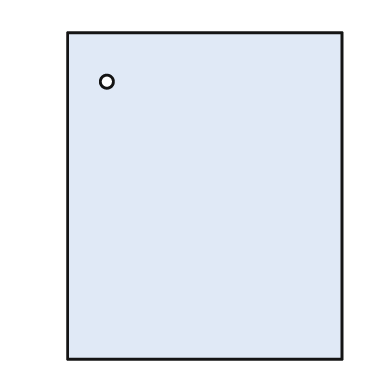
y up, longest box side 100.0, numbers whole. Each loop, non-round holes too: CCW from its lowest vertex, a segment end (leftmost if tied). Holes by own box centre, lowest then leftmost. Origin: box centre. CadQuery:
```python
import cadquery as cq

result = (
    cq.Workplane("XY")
    .moveTo(-42.0, -50.0)
    .lineTo(42.0, -50.0)
    .lineTo(42.0, 50.0)
    .lineTo(-42.0, 50.0)
    .close()
    .moveTo(-30.0, 35.0)
    .circle(2.0)
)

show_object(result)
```